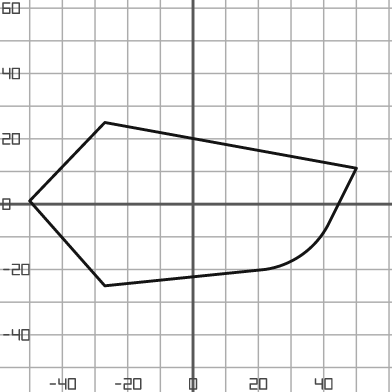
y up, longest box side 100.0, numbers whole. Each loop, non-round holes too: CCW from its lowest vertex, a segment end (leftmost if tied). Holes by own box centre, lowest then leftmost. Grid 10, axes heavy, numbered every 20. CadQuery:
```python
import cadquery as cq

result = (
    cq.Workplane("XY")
    .moveTo(-27.0, -25.0)
    .lineTo(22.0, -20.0)
    .threePointArc((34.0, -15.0), (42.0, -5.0))
    .lineTo(50.0, 11.0)
    .lineTo(-27.0, 25.0)
    .lineTo(-50.0, 1.0)
    .close()
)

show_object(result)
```